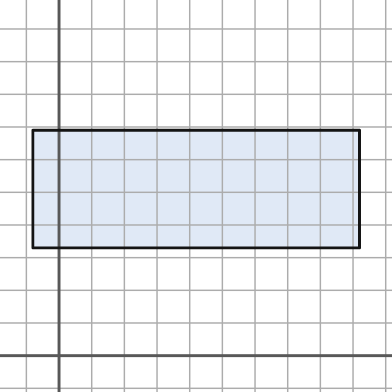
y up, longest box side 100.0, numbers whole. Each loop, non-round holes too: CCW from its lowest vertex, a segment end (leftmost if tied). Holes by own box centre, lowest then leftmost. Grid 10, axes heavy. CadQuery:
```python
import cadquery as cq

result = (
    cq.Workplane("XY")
    .moveTo(-8.0, 33.0)
    .lineTo(92.0, 33.0)
    .lineTo(92.0, 69.0)
    .lineTo(-8.0, 69.0)
    .close()
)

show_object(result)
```